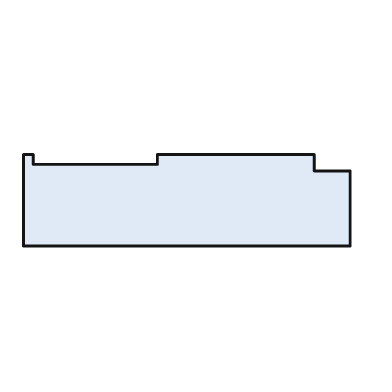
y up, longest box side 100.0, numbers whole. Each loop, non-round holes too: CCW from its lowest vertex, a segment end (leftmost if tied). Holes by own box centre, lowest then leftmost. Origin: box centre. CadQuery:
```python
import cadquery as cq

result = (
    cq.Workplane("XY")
    .moveTo(-50.0, -14.0)
    .lineTo(50.0, -14.0)
    .lineTo(50.0, 9.0)
    .lineTo(39.0, 9.0)
    .lineTo(39.0, 14.0)
    .lineTo(-9.0, 14.0)
    .lineTo(-9.0, 11.0)
    .lineTo(-47.0, 11.0)
    .lineTo(-47.0, 14.0)
    .lineTo(-50.0, 14.0)
    .close()
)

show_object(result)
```